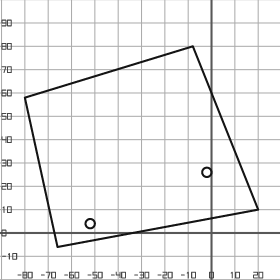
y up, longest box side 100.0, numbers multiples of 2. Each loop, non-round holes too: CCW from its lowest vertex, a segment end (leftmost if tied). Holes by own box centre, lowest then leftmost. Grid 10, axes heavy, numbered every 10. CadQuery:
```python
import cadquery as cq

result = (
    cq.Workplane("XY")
    .moveTo(-66.0, -6.0)
    .lineTo(20.0, 10.0)
    .lineTo(-8.0, 80.0)
    .lineTo(-80.0, 58.0)
    .close()
    .moveTo(-52.0, 4.0)
    .circle(2.0)
    .moveTo(-2.0, 26.0)
    .circle(2.0)
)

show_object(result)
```